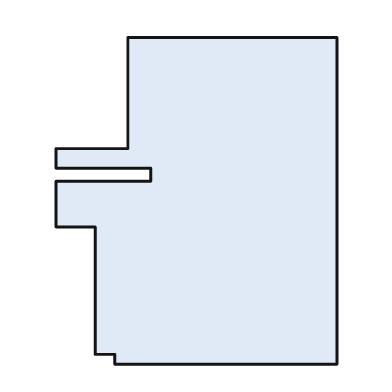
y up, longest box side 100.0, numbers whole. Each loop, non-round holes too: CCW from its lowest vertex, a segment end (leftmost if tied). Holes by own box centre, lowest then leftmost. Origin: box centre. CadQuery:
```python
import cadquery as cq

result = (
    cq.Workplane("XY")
    .moveTo(-25.0, -50.0)
    .lineTo(43.0, -50.0)
    .lineTo(43.0, 50.0)
    .lineTo(-21.0, 50.0)
    .lineTo(-21.0, 16.0)
    .lineTo(-43.0, 16.0)
    .lineTo(-43.0, 10.0)
    .lineTo(-14.0, 10.0)
    .lineTo(-14.0, 6.0)
    .lineTo(-43.0, 6.0)
    .lineTo(-43.0, -8.0)
    .lineTo(-31.0, -8.0)
    .lineTo(-31.0, -47.0)
    .lineTo(-25.0, -47.0)
    .close()
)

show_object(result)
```